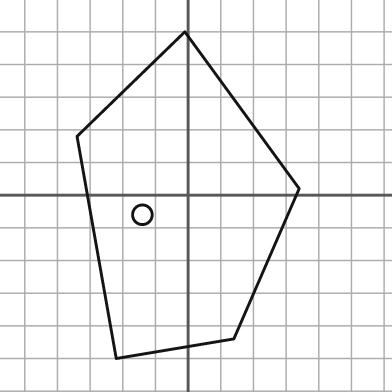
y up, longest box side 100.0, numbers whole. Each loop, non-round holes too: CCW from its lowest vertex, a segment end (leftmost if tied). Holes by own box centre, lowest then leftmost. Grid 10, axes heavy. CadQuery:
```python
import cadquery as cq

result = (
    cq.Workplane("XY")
    .moveTo(-22.0, -50.0)
    .lineTo(14.0, -44.0)
    .lineTo(34.0, 2.0)
    .lineTo(-1.0, 50.0)
    .lineTo(-34.0, 18.0)
    .close()
    .moveTo(-14.0, -6.0)
    .circle(3.0)
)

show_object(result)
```